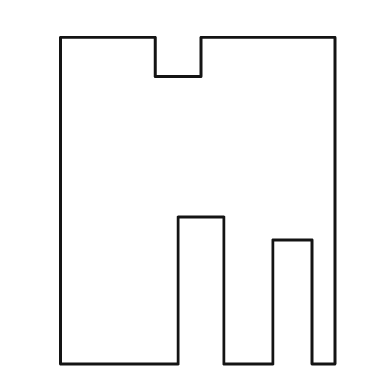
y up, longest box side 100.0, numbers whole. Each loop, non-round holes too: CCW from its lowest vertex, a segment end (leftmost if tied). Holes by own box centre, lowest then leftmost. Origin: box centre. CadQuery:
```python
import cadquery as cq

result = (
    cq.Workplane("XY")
    .moveTo(-42.0, -50.0)
    .lineTo(-6.0, -50.0)
    .lineTo(-6.0, -5.0)
    .lineTo(8.0, -5.0)
    .lineTo(8.0, -50.0)
    .lineTo(23.0, -50.0)
    .lineTo(23.0, -12.0)
    .lineTo(35.0, -12.0)
    .lineTo(35.0, -50.0)
    .lineTo(42.0, -50.0)
    .lineTo(42.0, 50.0)
    .lineTo(1.0, 50.0)
    .lineTo(1.0, 38.0)
    .lineTo(-13.0, 38.0)
    .lineTo(-13.0, 50.0)
    .lineTo(-42.0, 50.0)
    .close()
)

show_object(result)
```